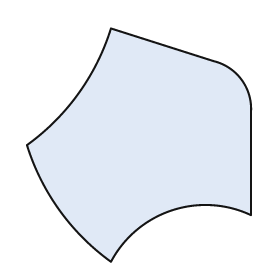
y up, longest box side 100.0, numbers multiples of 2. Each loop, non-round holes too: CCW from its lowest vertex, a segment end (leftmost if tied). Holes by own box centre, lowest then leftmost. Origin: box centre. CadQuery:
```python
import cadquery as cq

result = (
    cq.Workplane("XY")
    .moveTo(-12.0, -50.0)
    .threePointArc((14.0, -28.0), (48.0, -30.0))
    .lineTo(48.0, 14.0)
    .threePointArc((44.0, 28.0), (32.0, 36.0))
    .lineTo(-12.0, 50.0)
    .threePointArc((-26.0, 22.0), (-48.0, 0.0))
    .threePointArc((-34.0, -28.0), (-12.0, -50.0))
    .close()
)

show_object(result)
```